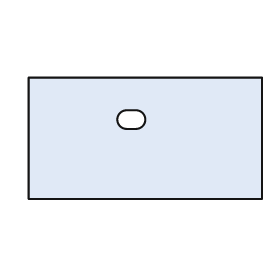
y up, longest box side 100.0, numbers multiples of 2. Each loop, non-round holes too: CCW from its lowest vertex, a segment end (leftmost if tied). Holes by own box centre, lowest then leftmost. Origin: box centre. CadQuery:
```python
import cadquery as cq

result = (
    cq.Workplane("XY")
    .moveTo(-50.0, -26.0)
    .lineTo(50.0, -26.0)
    .lineTo(50.0, 26.0)
    .lineTo(-50.0, 26.0)
    .close()
    .moveTo(-8.0, 4.0)
    .lineTo(-4.0, 4.0)
    .threePointArc((0.0, 8.0), (-4.0, 12.0))
    .lineTo(-8.0, 12.0)
    .threePointArc((-12.0, 8.0), (-8.0, 4.0))
    .close()
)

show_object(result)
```